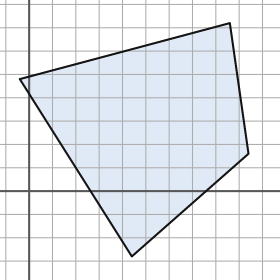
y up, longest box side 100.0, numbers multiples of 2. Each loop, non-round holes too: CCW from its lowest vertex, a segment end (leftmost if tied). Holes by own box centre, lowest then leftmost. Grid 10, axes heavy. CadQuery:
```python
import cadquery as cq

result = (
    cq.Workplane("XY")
    .moveTo(44.0, -28.0)
    .lineTo(94.0, 16.0)
    .lineTo(86.0, 72.0)
    .lineTo(-4.0, 48.0)
    .close()
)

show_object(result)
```